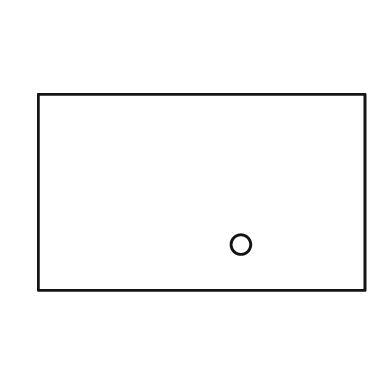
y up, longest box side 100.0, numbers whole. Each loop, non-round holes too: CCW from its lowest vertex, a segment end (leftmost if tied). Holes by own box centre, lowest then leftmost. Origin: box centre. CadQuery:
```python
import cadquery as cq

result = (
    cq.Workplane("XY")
    .moveTo(-50.0, -30.0)
    .lineTo(50.0, -30.0)
    .lineTo(50.0, 30.0)
    .lineTo(-50.0, 30.0)
    .close()
    .moveTo(12.0, -16.0)
    .circle(3.0)
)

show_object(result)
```